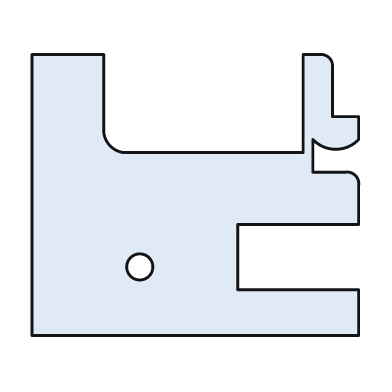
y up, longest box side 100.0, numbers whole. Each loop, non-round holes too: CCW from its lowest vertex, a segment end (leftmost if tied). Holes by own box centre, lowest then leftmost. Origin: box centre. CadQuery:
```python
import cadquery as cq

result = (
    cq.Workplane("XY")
    .moveTo(-50.0, -43.0)
    .lineTo(50.0, -43.0)
    .lineTo(50.0, -29.0)
    .lineTo(13.0, -29.0)
    .lineTo(13.0, -9.0)
    .lineTo(50.0, -9.0)
    .lineTo(50.0, 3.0)
    .threePointArc((49.0, 6.0), (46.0, 7.0))
    .lineTo(36.0, 7.0)
    .lineTo(36.0, 17.0)
    .threePointArc((43.0, 14.0), (50.0, 17.0))
    .lineTo(50.0, 24.0)
    .lineTo(42.0, 24.0)
    .lineTo(42.0, 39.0)
    .threePointArc((41.0, 42.0), (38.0, 43.0))
    .lineTo(33.0, 43.0)
    .lineTo(33.0, 13.0)
    .lineTo(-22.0, 13.0)
    .threePointArc((-26.0, 15.0), (-28.0, 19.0))
    .lineTo(-28.0, 43.0)
    .lineTo(-50.0, 43.0)
    .close()
    .moveTo(-17.0, -22.0)
    .circle(4.0)
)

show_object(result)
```